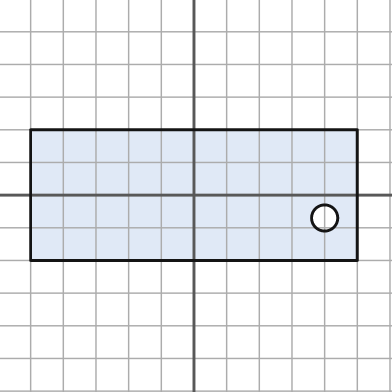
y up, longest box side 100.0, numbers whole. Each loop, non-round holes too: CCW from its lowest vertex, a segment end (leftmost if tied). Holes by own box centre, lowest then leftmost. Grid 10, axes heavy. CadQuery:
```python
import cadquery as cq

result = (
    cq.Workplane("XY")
    .moveTo(-50.0, -20.0)
    .lineTo(50.0, -20.0)
    .lineTo(50.0, 20.0)
    .lineTo(-50.0, 20.0)
    .close()
    .moveTo(40.0, -7.0)
    .circle(4.0)
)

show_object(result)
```